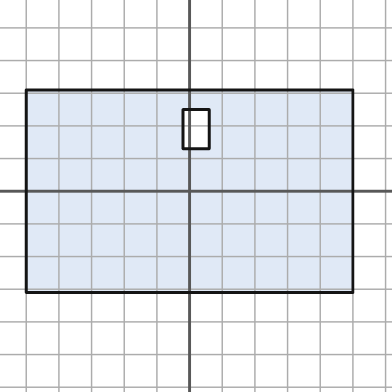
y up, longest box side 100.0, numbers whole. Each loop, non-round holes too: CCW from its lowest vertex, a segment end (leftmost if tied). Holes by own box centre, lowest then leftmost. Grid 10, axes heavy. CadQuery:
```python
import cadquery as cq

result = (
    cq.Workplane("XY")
    .moveTo(-50.0, -31.0)
    .lineTo(50.0, -31.0)
    .lineTo(50.0, 31.0)
    .lineTo(-50.0, 31.0)
    .close()
    .moveTo(-2.0, 13.0)
    .lineTo(6.0, 13.0)
    .lineTo(6.0, 25.0)
    .lineTo(-2.0, 25.0)
    .close()
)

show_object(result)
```